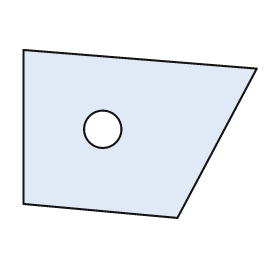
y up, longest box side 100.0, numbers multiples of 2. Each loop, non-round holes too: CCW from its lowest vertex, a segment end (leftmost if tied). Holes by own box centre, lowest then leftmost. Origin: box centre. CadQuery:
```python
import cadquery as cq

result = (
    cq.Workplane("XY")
    .moveTo(16.0, -36.0)
    .lineTo(50.0, 28.0)
    .lineTo(-50.0, 36.0)
    .lineTo(-50.0, -30.0)
    .close()
    .moveTo(-16.0, 2.0)
    .circle(8.0)
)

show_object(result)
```